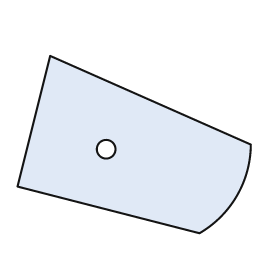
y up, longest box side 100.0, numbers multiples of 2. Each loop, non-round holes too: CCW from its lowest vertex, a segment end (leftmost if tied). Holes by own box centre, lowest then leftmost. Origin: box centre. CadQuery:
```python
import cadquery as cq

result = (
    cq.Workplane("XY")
    .moveTo(28.0, -38.0)
    .threePointArc((44.0, -22.0), (50.0, 0.0))
    .lineTo(-36.0, 38.0)
    .lineTo(-50.0, -18.0)
    .close()
    .moveTo(-12.0, -2.0)
    .circle(4.0)
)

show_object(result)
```